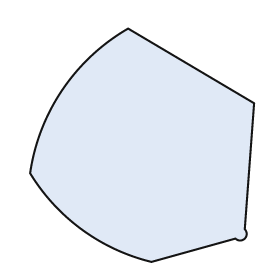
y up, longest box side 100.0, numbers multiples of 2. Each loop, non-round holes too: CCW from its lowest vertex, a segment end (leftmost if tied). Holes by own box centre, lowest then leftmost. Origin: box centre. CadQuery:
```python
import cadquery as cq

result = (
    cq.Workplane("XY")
    .moveTo(4.0, -50.0)
    .lineTo(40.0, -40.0)
    .threePointArc((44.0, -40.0), (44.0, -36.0))
    .lineTo(48.0, 18.0)
    .lineTo(-6.0, 50.0)
    .threePointArc((-34.0, 24.0), (-48.0, -12.0))
    .threePointArc((-26.0, -36.0), (4.0, -50.0))
    .close()
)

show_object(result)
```